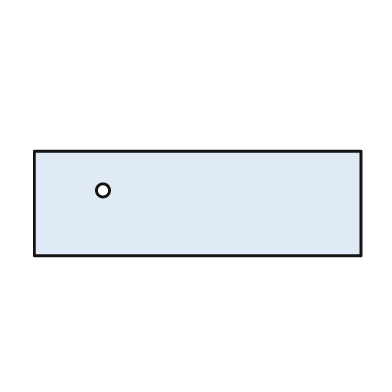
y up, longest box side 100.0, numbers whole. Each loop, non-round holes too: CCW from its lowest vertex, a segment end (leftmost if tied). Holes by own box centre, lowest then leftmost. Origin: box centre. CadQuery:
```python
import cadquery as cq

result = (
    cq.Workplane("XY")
    .moveTo(-50.0, -16.0)
    .lineTo(50.0, -16.0)
    .lineTo(50.0, 16.0)
    .lineTo(-50.0, 16.0)
    .close()
    .moveTo(-29.0, 4.0)
    .circle(2.0)
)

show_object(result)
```